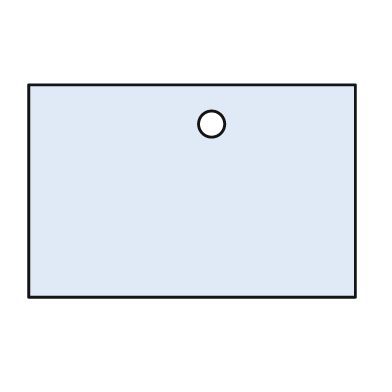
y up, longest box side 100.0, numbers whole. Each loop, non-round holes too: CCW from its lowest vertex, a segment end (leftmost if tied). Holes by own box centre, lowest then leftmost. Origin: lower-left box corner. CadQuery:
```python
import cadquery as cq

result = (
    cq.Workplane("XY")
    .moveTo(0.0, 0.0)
    .lineTo(100.0, 0.0)
    .lineTo(100.0, 65.0)
    .lineTo(0.0, 65.0)
    .close()
    .moveTo(56.0, 53.0)
    .circle(4.0)
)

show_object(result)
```